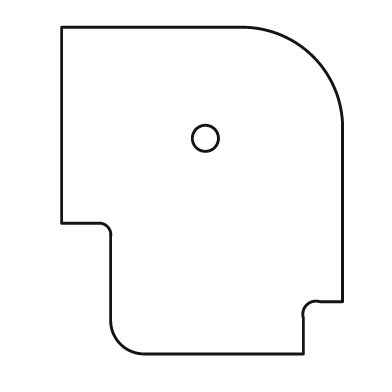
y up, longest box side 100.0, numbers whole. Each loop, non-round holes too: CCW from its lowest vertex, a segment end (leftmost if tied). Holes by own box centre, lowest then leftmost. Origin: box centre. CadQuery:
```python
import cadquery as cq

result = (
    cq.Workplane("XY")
    .moveTo(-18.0, -50.0)
    .lineTo(31.0, -50.0)
    .lineTo(31.0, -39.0)
    .threePointArc((32.0, -35.0), (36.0, -34.0))
    .lineTo(43.0, -34.0)
    .lineTo(43.0, 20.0)
    .threePointArc((34.0, 41.0), (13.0, 50.0))
    .lineTo(-43.0, 50.0)
    .lineTo(-43.0, -10.0)
    .lineTo(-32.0, -10.0)
    .threePointArc((-29.0, -11.0), (-28.0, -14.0))
    .lineTo(-28.0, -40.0)
    .threePointArc((-25.0, -47.0), (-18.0, -50.0))
    .close()
    .moveTo(1.0, 16.0)
    .circle(4.0)
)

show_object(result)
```